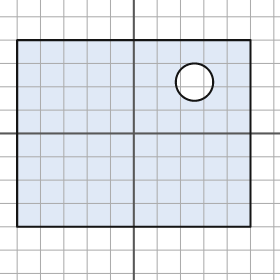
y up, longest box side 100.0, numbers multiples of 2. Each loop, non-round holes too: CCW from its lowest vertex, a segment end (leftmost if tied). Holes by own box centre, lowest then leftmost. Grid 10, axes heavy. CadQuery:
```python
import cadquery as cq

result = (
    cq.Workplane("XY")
    .moveTo(-50.0, -40.0)
    .lineTo(50.0, -40.0)
    .lineTo(50.0, 40.0)
    .lineTo(-50.0, 40.0)
    .close()
    .moveTo(26.0, 22.0)
    .circle(8.0)
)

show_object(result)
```